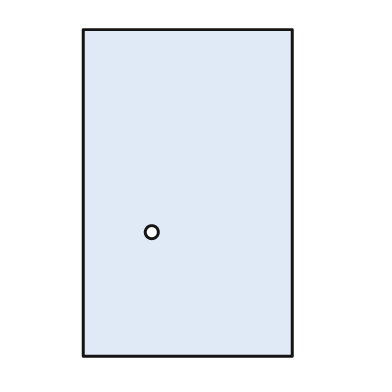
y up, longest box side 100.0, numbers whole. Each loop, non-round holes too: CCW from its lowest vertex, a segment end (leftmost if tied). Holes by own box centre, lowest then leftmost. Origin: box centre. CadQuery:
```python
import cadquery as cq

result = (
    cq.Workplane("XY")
    .moveTo(-32.0, -50.0)
    .lineTo(32.0, -50.0)
    .lineTo(32.0, 50.0)
    .lineTo(-32.0, 50.0)
    .close()
    .moveTo(-11.0, -12.0)
    .circle(2.0)
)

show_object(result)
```